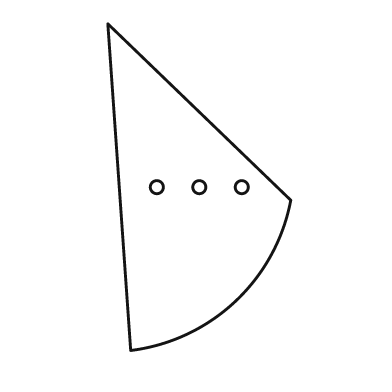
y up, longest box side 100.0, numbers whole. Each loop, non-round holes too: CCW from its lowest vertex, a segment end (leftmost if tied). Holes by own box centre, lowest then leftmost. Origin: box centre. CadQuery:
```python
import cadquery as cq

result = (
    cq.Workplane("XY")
    .moveTo(-21.0, -50.0)
    .threePointArc((11.0, -35.0), (28.0, -4.0))
    .lineTo(-28.0, 50.0)
    .close()
    .moveTo(-13.0, 0.0)
    .circle(2.0)
    .moveTo(0.0, 0.0)
    .circle(2.0)
    .moveTo(13.0, 0.0)
    .circle(2.0)
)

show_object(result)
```